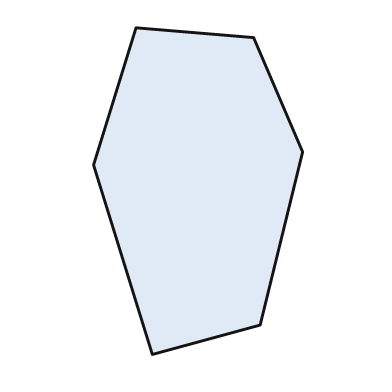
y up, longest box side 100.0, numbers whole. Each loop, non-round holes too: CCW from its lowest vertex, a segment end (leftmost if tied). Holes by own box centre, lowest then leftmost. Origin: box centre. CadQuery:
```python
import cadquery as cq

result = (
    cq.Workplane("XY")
    .moveTo(-14.0, -50.0)
    .lineTo(19.0, -41.0)
    .lineTo(32.0, 12.0)
    .lineTo(17.0, 47.0)
    .lineTo(-19.0, 50.0)
    .lineTo(-32.0, 8.0)
    .close()
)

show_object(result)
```